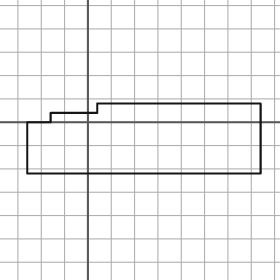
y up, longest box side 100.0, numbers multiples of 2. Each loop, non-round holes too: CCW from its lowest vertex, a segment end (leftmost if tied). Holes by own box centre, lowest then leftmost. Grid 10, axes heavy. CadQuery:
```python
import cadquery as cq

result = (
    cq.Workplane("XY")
    .moveTo(-26.0, -22.0)
    .lineTo(74.0, -22.0)
    .lineTo(74.0, 8.0)
    .lineTo(4.0, 8.0)
    .lineTo(4.0, 4.0)
    .lineTo(-16.0, 4.0)
    .lineTo(-16.0, 0.0)
    .lineTo(-26.0, 0.0)
    .close()
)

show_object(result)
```